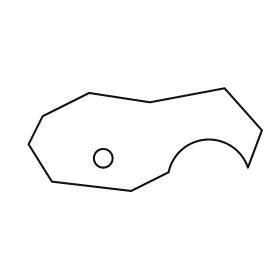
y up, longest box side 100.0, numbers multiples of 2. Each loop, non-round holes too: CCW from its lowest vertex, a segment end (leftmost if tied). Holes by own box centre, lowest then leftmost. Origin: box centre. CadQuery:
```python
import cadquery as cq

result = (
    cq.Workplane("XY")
    .moveTo(-6.0, -22.0)
    .lineTo(10.0, -14.0)
    .threePointArc((26.0, 0.0), (44.0, -12.0))
    .lineTo(50.0, 4.0)
    .lineTo(34.0, 22.0)
    .lineTo(2.0, 16.0)
    .lineTo(-24.0, 20.0)
    .lineTo(-44.0, 10.0)
    .lineTo(-50.0, -2.0)
    .lineTo(-40.0, -18.0)
    .close()
    .moveTo(-18.0, -8.0)
    .circle(4.0)
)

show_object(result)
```